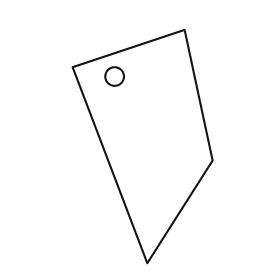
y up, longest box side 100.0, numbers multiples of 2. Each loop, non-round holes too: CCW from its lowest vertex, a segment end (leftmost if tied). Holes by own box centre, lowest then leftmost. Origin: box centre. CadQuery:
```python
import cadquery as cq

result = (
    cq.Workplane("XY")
    .moveTo(2.0, -50.0)
    .lineTo(30.0, -6.0)
    .lineTo(18.0, 50.0)
    .lineTo(-30.0, 34.0)
    .close()
    .moveTo(-12.0, 30.0)
    .circle(4.0)
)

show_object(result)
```